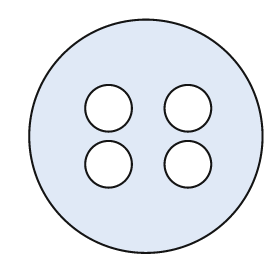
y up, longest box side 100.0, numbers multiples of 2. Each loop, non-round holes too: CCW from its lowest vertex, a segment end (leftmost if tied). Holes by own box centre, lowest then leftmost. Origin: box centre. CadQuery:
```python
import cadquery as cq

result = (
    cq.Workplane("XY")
    .moveTo(0.0, 0.0)
    .circle(50.0)
    .moveTo(-16.0, -12.0)
    .circle(10.0)
    .moveTo(18.0, -12.0)
    .circle(10.0)
    .moveTo(-16.0, 12.0)
    .circle(10.0)
    .moveTo(18.0, 12.0)
    .circle(10.0)
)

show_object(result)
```